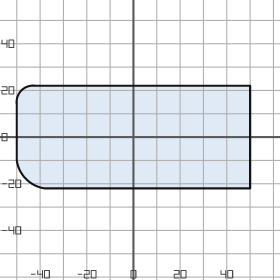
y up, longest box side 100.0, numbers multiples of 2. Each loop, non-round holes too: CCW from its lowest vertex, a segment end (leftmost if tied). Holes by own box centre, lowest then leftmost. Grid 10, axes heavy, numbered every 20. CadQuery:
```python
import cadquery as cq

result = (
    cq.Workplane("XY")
    .moveTo(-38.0, -22.0)
    .lineTo(50.0, -22.0)
    .lineTo(50.0, 22.0)
    .lineTo(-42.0, 22.0)
    .threePointArc((-48.0, 20.0), (-50.0, 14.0))
    .lineTo(-50.0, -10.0)
    .threePointArc((-46.0, -18.0), (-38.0, -22.0))
    .close()
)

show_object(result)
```